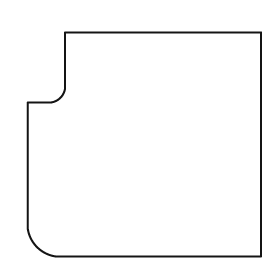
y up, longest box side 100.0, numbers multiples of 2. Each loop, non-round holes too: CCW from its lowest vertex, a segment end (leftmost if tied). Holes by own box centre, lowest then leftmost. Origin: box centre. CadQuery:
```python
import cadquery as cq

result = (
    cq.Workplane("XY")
    .moveTo(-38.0, -48.0)
    .lineTo(50.0, -48.0)
    .lineTo(50.0, 48.0)
    .lineTo(-34.0, 48.0)
    .lineTo(-34.0, 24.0)
    .threePointArc((-36.0, 20.0), (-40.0, 18.0))
    .lineTo(-50.0, 18.0)
    .lineTo(-50.0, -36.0)
    .threePointArc((-46.0, -44.0), (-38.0, -48.0))
    .close()
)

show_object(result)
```